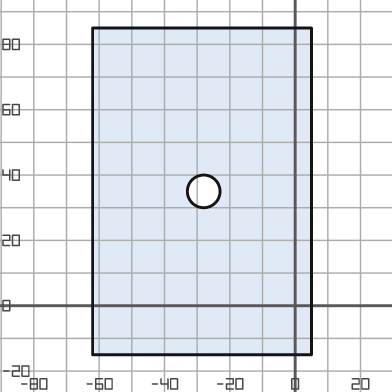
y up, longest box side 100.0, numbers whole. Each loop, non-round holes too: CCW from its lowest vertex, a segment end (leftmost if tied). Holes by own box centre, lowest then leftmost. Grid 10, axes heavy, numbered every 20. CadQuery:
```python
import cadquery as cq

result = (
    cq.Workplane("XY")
    .moveTo(-62.0, -15.0)
    .lineTo(5.0, -15.0)
    .lineTo(5.0, 85.0)
    .lineTo(-62.0, 85.0)
    .close()
    .moveTo(-28.0, 35.0)
    .circle(5.0)
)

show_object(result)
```